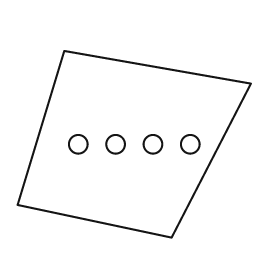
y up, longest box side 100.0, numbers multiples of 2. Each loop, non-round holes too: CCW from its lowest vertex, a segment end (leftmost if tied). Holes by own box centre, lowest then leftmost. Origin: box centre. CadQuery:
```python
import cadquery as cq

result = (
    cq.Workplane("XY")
    .moveTo(16.0, -40.0)
    .lineTo(50.0, 26.0)
    .lineTo(-30.0, 40.0)
    .lineTo(-50.0, -26.0)
    .close()
    .moveTo(-24.0, 0.0)
    .circle(4.0)
    .moveTo(-8.0, 0.0)
    .circle(4.0)
    .moveTo(8.0, 0.0)
    .circle(4.0)
    .moveTo(24.0, 0.0)
    .circle(4.0)
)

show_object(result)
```